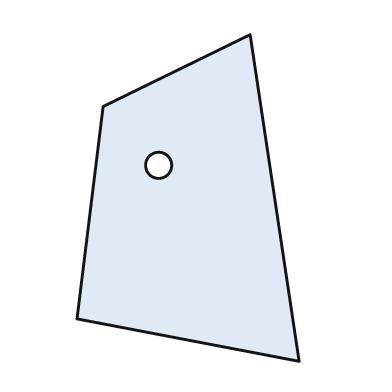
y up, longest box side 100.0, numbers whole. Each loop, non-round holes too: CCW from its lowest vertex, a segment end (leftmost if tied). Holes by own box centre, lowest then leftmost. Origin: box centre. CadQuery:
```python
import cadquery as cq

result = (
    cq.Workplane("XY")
    .moveTo(34.0, -50.0)
    .lineTo(19.0, 50.0)
    .lineTo(-26.0, 28.0)
    .lineTo(-34.0, -37.0)
    .close()
    .moveTo(-9.0, 10.0)
    .circle(4.0)
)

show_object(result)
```